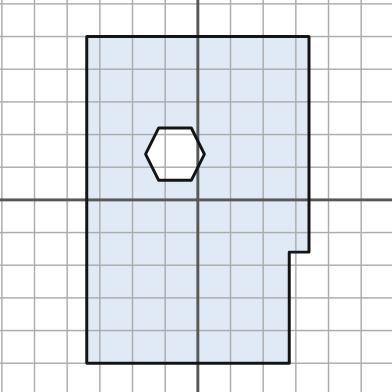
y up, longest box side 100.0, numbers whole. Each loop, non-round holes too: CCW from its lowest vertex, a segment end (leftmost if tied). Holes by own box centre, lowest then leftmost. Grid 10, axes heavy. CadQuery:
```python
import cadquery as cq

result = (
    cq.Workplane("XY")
    .moveTo(-34.0, -50.0)
    .lineTo(28.0, -50.0)
    .lineTo(28.0, -16.0)
    .lineTo(34.0, -16.0)
    .lineTo(34.0, 50.0)
    .lineTo(-34.0, 50.0)
    .close()
    .moveTo(-12.0, 6.0)
    .lineTo(-2.0, 6.0)
    .lineTo(2.0, 14.0)
    .lineTo(-2.0, 22.0)
    .lineTo(-12.0, 22.0)
    .lineTo(-16.0, 14.0)
    .close()
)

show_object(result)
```